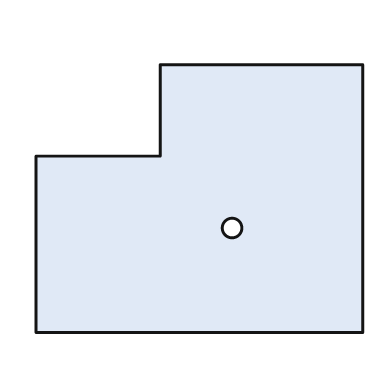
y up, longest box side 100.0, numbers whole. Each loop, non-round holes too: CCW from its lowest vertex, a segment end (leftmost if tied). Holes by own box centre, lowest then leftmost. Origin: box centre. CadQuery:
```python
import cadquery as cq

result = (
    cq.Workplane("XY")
    .moveTo(-50.0, -41.0)
    .lineTo(50.0, -41.0)
    .lineTo(50.0, 41.0)
    .lineTo(-12.0, 41.0)
    .lineTo(-12.0, 13.0)
    .lineTo(-50.0, 13.0)
    .close()
    .moveTo(10.0, -9.0)
    .circle(3.0)
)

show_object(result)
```